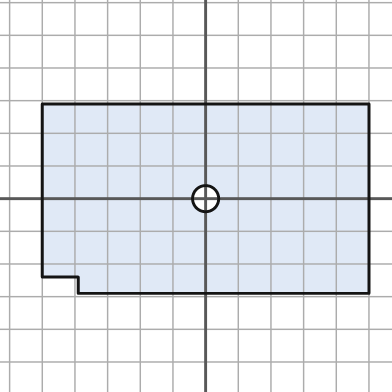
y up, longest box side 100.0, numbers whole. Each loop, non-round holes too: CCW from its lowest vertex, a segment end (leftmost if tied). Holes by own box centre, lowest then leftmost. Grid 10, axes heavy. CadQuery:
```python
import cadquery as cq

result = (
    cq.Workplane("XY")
    .moveTo(-39.0, -29.0)
    .lineTo(50.0, -29.0)
    .lineTo(50.0, 29.0)
    .lineTo(-50.0, 29.0)
    .lineTo(-50.0, -24.0)
    .lineTo(-39.0, -24.0)
    .close()
    .moveTo(0.0, 0.0)
    .circle(4.0)
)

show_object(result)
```